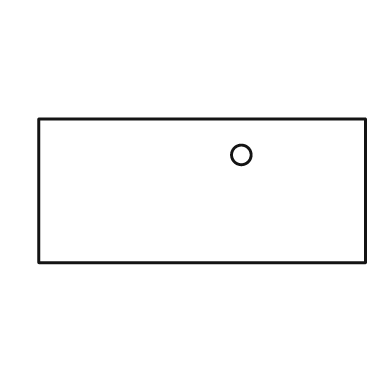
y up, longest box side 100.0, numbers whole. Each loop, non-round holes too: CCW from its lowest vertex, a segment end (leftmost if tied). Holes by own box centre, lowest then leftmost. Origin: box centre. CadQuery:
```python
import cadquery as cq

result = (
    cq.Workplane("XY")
    .moveTo(-50.0, -22.0)
    .lineTo(50.0, -22.0)
    .lineTo(50.0, 22.0)
    .lineTo(-50.0, 22.0)
    .close()
    .moveTo(12.0, 11.0)
    .circle(3.0)
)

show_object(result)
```